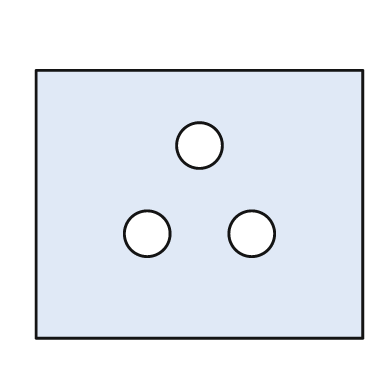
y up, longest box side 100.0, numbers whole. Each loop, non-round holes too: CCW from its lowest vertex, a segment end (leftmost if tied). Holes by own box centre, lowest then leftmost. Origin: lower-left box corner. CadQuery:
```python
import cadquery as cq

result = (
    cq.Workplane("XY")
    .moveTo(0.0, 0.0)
    .lineTo(100.0, 0.0)
    .lineTo(100.0, 82.0)
    .lineTo(0.0, 82.0)
    .close()
    .moveTo(34.0, 32.0)
    .circle(7.0)
    .moveTo(66.0, 32.0)
    .circle(7.0)
    .moveTo(50.0, 59.0)
    .circle(7.0)
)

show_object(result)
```